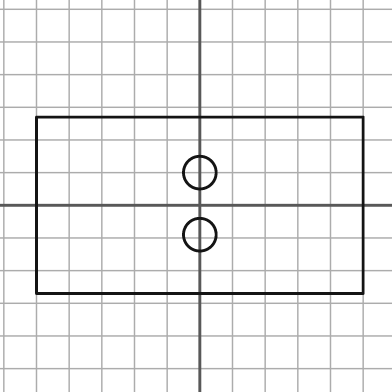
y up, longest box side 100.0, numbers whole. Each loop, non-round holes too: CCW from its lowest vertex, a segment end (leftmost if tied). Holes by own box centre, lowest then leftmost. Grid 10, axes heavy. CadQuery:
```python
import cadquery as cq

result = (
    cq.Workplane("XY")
    .moveTo(-50.0, -27.0)
    .lineTo(50.0, -27.0)
    .lineTo(50.0, 27.0)
    .lineTo(-50.0, 27.0)
    .close()
    .moveTo(0.0, -9.0)
    .circle(5.0)
    .moveTo(0.0, 10.0)
    .circle(5.0)
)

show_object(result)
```